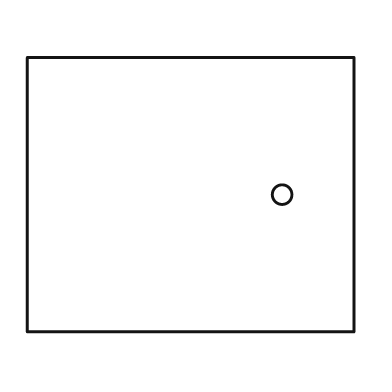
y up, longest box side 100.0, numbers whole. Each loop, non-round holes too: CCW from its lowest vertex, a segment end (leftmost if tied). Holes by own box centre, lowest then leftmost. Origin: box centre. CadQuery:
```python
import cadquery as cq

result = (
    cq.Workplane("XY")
    .moveTo(-50.0, -42.0)
    .lineTo(50.0, -42.0)
    .lineTo(50.0, 42.0)
    .lineTo(-50.0, 42.0)
    .close()
    .moveTo(28.0, 0.0)
    .circle(3.0)
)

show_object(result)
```